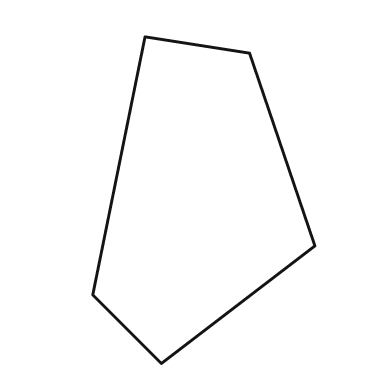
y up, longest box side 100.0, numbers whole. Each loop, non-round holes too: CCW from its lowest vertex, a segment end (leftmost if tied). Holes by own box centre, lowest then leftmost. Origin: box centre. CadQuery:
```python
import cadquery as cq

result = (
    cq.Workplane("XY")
    .moveTo(-13.0, -50.0)
    .lineTo(34.0, -14.0)
    .lineTo(14.0, 45.0)
    .lineTo(-18.0, 50.0)
    .lineTo(-34.0, -29.0)
    .close()
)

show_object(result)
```